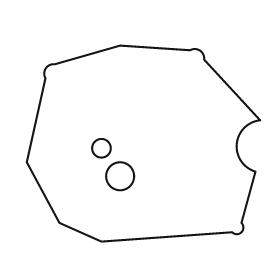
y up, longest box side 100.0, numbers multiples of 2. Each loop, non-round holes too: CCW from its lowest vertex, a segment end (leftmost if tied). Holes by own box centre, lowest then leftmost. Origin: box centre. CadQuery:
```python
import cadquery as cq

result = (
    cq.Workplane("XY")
    .moveTo(-18.0, -42.0)
    .lineTo(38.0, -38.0)
    .threePointArc((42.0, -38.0), (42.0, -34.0))
    .lineTo(48.0, -12.0)
    .threePointArc((40.0, 0.0), (50.0, 10.0))
    .lineTo(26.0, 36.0)
    .threePointArc((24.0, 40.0), (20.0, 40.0))
    .lineTo(-10.0, 42.0)
    .lineTo(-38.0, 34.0)
    .threePointArc((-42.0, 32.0), (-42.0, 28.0))
    .lineTo(-50.0, -8.0)
    .lineTo(-36.0, -34.0)
    .close()
    .moveTo(-10.0, -14.0)
    .circle(6.0)
    .moveTo(-18.0, -2.0)
    .circle(4.0)
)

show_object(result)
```